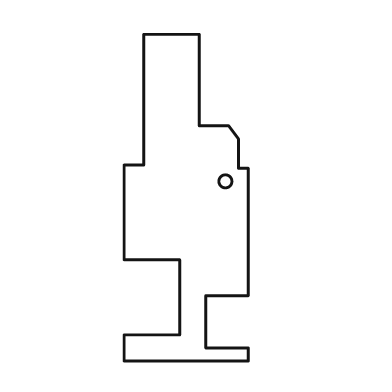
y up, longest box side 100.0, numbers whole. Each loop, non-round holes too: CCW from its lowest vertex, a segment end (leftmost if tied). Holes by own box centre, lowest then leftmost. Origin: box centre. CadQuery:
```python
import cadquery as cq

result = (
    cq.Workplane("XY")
    .moveTo(-19.0, -50.0)
    .lineTo(19.0, -50.0)
    .lineTo(19.0, -46.0)
    .lineTo(6.0, -46.0)
    .lineTo(6.0, -30.0)
    .lineTo(19.0, -30.0)
    .lineTo(19.0, 9.0)
    .lineTo(16.0, 9.0)
    .lineTo(16.0, 18.0)
    .lineTo(13.0, 22.0)
    .lineTo(4.0, 22.0)
    .lineTo(4.0, 50.0)
    .lineTo(-13.0, 50.0)
    .lineTo(-13.0, 10.0)
    .lineTo(-19.0, 10.0)
    .lineTo(-19.0, -19.0)
    .lineTo(-2.0, -19.0)
    .lineTo(-2.0, -42.0)
    .lineTo(-19.0, -42.0)
    .close()
    .moveTo(12.0, 5.0)
    .circle(2.0)
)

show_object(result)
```